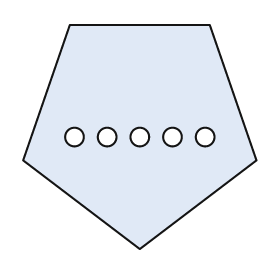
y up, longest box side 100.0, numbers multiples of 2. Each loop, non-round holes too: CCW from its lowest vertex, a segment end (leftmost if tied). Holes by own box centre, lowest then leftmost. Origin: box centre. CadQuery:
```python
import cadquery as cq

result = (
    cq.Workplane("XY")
    .moveTo(0.0, -48.0)
    .lineTo(50.0, -10.0)
    .lineTo(30.0, 48.0)
    .lineTo(-30.0, 48.0)
    .lineTo(-50.0, -10.0)
    .close()
    .moveTo(-28.0, 0.0)
    .circle(4.0)
    .moveTo(-14.0, 0.0)
    .circle(4.0)
    .moveTo(0.0, 0.0)
    .circle(4.0)
    .moveTo(14.0, 0.0)
    .circle(4.0)
    .moveTo(28.0, 0.0)
    .circle(4.0)
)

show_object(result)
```